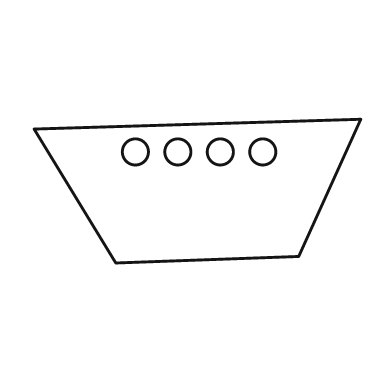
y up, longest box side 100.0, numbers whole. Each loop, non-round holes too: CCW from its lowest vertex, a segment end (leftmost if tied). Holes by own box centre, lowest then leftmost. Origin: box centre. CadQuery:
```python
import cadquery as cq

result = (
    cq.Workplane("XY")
    .moveTo(-25.0, -22.0)
    .lineTo(31.0, -20.0)
    .lineTo(50.0, 22.0)
    .lineTo(-50.0, 19.0)
    .close()
    .moveTo(-19.0, 12.0)
    .circle(4.0)
    .moveTo(-6.0, 12.0)
    .circle(4.0)
    .moveTo(7.0, 12.0)
    .circle(4.0)
    .moveTo(20.0, 12.0)
    .circle(4.0)
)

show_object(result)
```